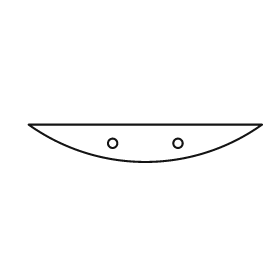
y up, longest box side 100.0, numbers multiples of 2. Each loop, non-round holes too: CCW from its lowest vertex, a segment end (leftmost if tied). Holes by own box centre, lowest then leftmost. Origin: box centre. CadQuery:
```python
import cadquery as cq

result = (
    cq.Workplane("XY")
    .moveTo(-50.0, 8.0)
    .threePointArc((0.0, -8.0), (50.0, 8.0))
    .close()
    .moveTo(-14.0, 0.0)
    .circle(2.0)
    .moveTo(14.0, 0.0)
    .circle(2.0)
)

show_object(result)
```